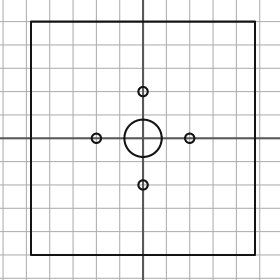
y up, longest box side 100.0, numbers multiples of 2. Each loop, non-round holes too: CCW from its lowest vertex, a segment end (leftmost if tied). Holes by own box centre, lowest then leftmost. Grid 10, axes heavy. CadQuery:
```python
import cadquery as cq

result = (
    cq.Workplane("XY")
    .moveTo(-48.0, -50.0)
    .lineTo(48.0, -50.0)
    .lineTo(48.0, 50.0)
    .lineTo(-48.0, 50.0)
    .close()
    .moveTo(0.0, -20.0)
    .circle(2.0)
    .moveTo(-20.0, 0.0)
    .circle(2.0)
    .moveTo(0.0, 0.0)
    .circle(8.0)
    .moveTo(20.0, 0.0)
    .circle(2.0)
    .moveTo(0.0, 20.0)
    .circle(2.0)
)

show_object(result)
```